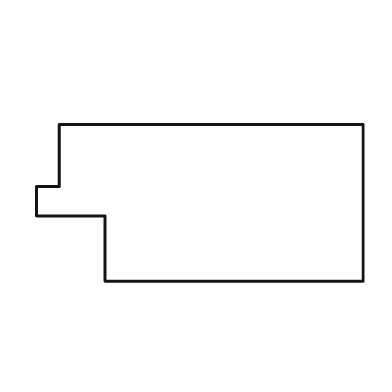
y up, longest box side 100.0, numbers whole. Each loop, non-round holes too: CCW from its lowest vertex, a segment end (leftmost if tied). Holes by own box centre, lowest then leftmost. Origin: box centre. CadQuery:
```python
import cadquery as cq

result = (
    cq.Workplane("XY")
    .moveTo(-29.0, -24.0)
    .lineTo(50.0, -24.0)
    .lineTo(50.0, 24.0)
    .lineTo(-43.0, 24.0)
    .lineTo(-43.0, 5.0)
    .lineTo(-50.0, 5.0)
    .lineTo(-50.0, -4.0)
    .lineTo(-29.0, -4.0)
    .close()
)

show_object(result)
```